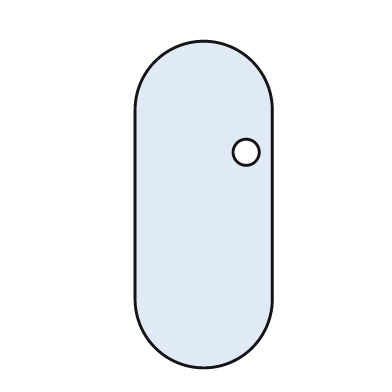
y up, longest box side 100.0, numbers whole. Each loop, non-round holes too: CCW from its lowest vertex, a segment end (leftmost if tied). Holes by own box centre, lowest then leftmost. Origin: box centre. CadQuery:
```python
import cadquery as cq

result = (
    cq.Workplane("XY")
    .moveTo(-21.0, -29.0)
    .threePointArc((0.0, -50.0), (21.0, -29.0))
    .lineTo(21.0, 29.0)
    .threePointArc((0.0, 50.0), (-21.0, 29.0))
    .close()
    .moveTo(13.0, 16.0)
    .circle(4.0)
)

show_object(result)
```